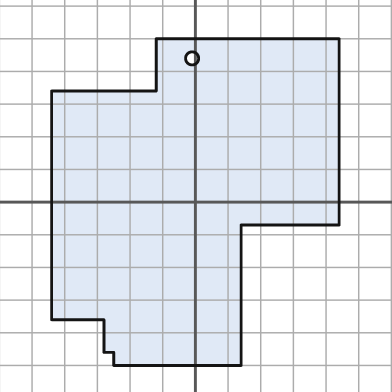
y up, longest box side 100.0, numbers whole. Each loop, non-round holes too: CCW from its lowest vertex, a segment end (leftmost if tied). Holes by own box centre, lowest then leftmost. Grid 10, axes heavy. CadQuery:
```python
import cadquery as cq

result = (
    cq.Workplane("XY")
    .moveTo(-25.0, -50.0)
    .lineTo(14.0, -50.0)
    .lineTo(14.0, -7.0)
    .lineTo(44.0, -7.0)
    .lineTo(44.0, 50.0)
    .lineTo(-12.0, 50.0)
    .lineTo(-12.0, 34.0)
    .lineTo(-44.0, 34.0)
    .lineTo(-44.0, -36.0)
    .lineTo(-28.0, -36.0)
    .lineTo(-28.0, -46.0)
    .lineTo(-25.0, -46.0)
    .close()
    .moveTo(-1.0, 44.0)
    .circle(2.0)
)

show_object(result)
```